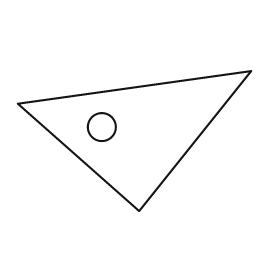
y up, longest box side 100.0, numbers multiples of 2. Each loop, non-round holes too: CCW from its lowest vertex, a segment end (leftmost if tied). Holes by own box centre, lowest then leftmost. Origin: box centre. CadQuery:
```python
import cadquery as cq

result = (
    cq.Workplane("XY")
    .moveTo(2.0, -30.0)
    .lineTo(50.0, 30.0)
    .lineTo(-50.0, 16.0)
    .close()
    .moveTo(-14.0, 6.0)
    .circle(6.0)
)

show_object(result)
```